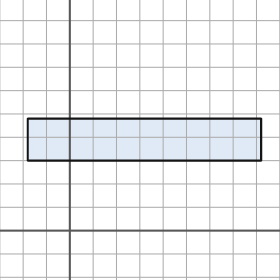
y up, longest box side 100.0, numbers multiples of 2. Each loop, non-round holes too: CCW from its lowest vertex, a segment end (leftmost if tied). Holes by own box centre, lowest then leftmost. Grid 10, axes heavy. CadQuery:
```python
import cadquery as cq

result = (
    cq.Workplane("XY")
    .moveTo(-18.0, 30.0)
    .lineTo(82.0, 30.0)
    .lineTo(82.0, 48.0)
    .lineTo(-18.0, 48.0)
    .close()
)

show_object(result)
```